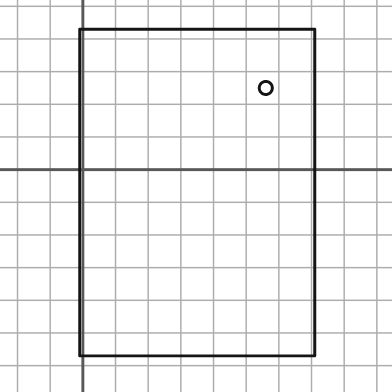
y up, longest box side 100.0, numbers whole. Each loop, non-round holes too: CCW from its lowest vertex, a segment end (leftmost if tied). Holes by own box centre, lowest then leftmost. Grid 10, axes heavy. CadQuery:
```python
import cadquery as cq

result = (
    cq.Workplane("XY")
    .moveTo(-1.0, -57.0)
    .lineTo(71.0, -57.0)
    .lineTo(71.0, 43.0)
    .lineTo(-1.0, 43.0)
    .close()
    .moveTo(56.0, 25.0)
    .circle(2.0)
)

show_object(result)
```